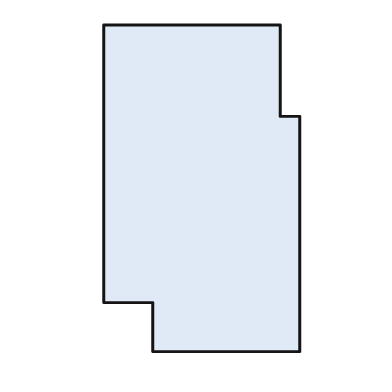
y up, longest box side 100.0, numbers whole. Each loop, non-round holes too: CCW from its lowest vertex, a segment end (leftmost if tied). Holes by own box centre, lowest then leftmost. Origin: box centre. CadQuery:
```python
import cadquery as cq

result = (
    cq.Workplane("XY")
    .moveTo(-15.0, -50.0)
    .lineTo(30.0, -50.0)
    .lineTo(30.0, 22.0)
    .lineTo(24.0, 22.0)
    .lineTo(24.0, 50.0)
    .lineTo(-30.0, 50.0)
    .lineTo(-30.0, -35.0)
    .lineTo(-15.0, -35.0)
    .close()
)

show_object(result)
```